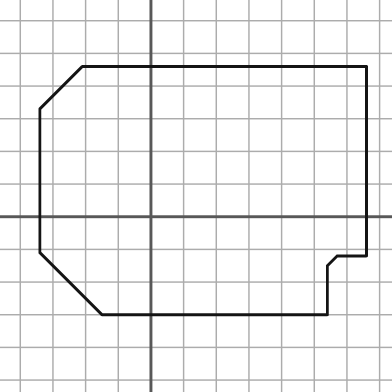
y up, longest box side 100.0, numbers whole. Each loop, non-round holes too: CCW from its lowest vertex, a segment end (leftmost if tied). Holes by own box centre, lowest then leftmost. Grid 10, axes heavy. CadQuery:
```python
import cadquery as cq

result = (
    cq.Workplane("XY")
    .moveTo(-15.0, -30.0)
    .lineTo(54.0, -30.0)
    .lineTo(54.0, -15.0)
    .lineTo(57.0, -12.0)
    .lineTo(66.0, -12.0)
    .lineTo(66.0, 46.0)
    .lineTo(-21.0, 46.0)
    .lineTo(-34.0, 33.0)
    .lineTo(-34.0, -11.0)
    .close()
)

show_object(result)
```